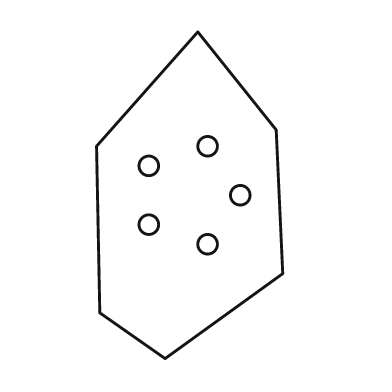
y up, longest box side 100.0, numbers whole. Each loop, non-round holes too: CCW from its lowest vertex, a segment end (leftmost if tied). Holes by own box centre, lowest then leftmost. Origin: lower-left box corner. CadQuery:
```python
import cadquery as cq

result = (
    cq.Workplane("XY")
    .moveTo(21.0, 0.0)
    .lineTo(57.0, 26.0)
    .lineTo(55.0, 70.0)
    .lineTo(31.0, 100.0)
    .lineTo(0.0, 65.0)
    .lineTo(1.0, 14.0)
    .close()
    .moveTo(34.0, 35.0)
    .circle(3.0)
    .moveTo(16.0, 41.0)
    .circle(3.0)
    .moveTo(44.0, 50.0)
    .circle(3.0)
    .moveTo(16.0, 59.0)
    .circle(3.0)
    .moveTo(34.0, 65.0)
    .circle(3.0)
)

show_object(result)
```